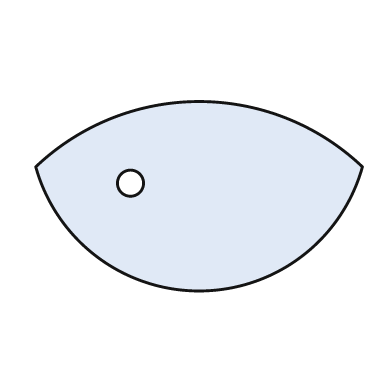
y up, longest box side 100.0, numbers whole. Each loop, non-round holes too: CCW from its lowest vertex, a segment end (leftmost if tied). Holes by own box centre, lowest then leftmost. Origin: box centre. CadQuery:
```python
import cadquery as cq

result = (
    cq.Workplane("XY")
    .moveTo(-50.0, 9.0)
    .threePointArc((0.0, -29.0), (50.0, 9.0))
    .threePointArc((0.0, 29.0), (-50.0, 9.0))
    .close()
    .moveTo(-21.0, 4.0)
    .circle(4.0)
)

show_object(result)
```